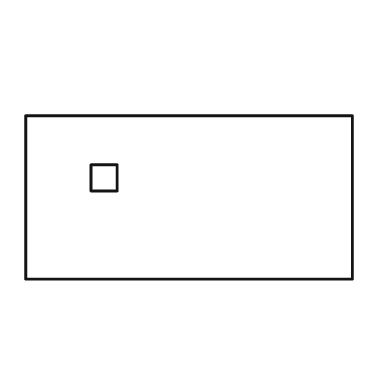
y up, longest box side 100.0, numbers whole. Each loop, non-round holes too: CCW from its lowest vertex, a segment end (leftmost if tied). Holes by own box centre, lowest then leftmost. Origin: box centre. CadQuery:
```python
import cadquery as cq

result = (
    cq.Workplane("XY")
    .moveTo(-50.0, -25.0)
    .lineTo(50.0, -25.0)
    .lineTo(50.0, 25.0)
    .lineTo(-50.0, 25.0)
    .close()
    .moveTo(-30.0, 2.0)
    .lineTo(-22.0, 2.0)
    .lineTo(-22.0, 10.0)
    .lineTo(-30.0, 10.0)
    .close()
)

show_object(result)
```